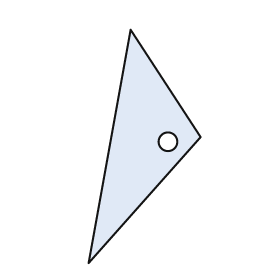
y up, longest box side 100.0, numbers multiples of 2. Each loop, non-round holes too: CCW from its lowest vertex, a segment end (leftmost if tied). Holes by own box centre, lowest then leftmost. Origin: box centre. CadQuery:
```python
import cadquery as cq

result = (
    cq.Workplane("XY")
    .moveTo(-24.0, -50.0)
    .lineTo(24.0, 4.0)
    .lineTo(-6.0, 50.0)
    .close()
    .moveTo(10.0, 2.0)
    .circle(4.0)
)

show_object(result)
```